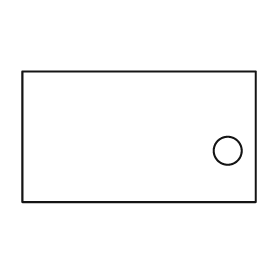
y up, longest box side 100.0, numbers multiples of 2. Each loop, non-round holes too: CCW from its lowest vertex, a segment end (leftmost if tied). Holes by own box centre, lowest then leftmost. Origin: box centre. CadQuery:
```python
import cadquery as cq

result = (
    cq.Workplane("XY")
    .moveTo(-50.0, -28.0)
    .lineTo(50.0, -28.0)
    .lineTo(50.0, 28.0)
    .lineTo(-50.0, 28.0)
    .close()
    .moveTo(38.0, -6.0)
    .circle(6.0)
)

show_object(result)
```